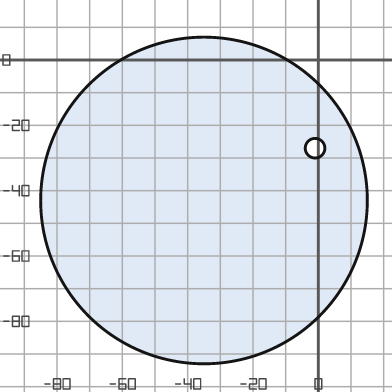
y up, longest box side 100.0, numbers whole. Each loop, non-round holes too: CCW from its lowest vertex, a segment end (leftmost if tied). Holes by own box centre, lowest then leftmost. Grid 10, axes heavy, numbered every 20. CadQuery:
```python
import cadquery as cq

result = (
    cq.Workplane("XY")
    .moveTo(-35.0, -43.0)
    .circle(50.0)
    .moveTo(-1.0, -27.0)
    .circle(3.0)
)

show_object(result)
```